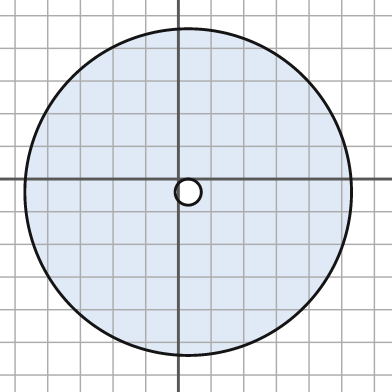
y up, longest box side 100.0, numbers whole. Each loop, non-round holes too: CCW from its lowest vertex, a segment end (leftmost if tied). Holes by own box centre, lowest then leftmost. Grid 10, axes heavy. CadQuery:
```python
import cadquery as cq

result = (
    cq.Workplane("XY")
    .moveTo(3.0, -4.0)
    .circle(50.0)
    .moveTo(3.0, -4.0)
    .circle(4.0)
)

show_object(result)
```